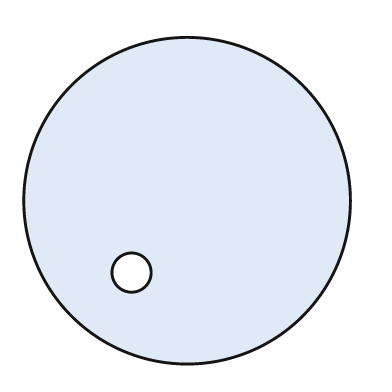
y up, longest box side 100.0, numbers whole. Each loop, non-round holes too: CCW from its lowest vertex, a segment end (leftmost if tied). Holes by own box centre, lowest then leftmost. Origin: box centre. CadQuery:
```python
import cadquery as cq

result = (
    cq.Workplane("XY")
    .moveTo(0.0, 0.0)
    .circle(50.0)
    .moveTo(-17.0, -22.0)
    .circle(6.0)
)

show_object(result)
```